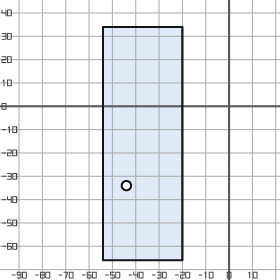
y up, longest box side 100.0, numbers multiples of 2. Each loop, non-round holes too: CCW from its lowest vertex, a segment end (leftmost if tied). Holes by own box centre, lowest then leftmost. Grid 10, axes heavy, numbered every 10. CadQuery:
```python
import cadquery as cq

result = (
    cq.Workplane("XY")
    .moveTo(-54.0, -66.0)
    .lineTo(-20.0, -66.0)
    .lineTo(-20.0, 34.0)
    .lineTo(-54.0, 34.0)
    .close()
    .moveTo(-44.0, -34.0)
    .circle(2.0)
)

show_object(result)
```